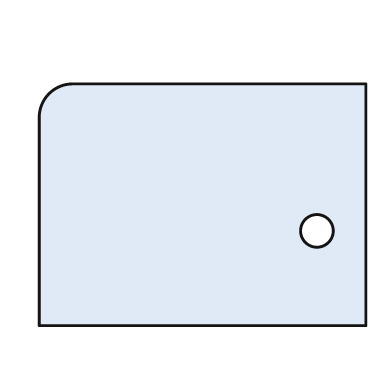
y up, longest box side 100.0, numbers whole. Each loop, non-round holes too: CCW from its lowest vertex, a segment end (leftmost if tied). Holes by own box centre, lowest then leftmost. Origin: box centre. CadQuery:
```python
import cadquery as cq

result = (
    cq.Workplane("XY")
    .moveTo(-50.0, -37.0)
    .lineTo(50.0, -37.0)
    .lineTo(50.0, 37.0)
    .lineTo(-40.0, 37.0)
    .threePointArc((-47.0, 34.0), (-50.0, 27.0))
    .close()
    .moveTo(35.0, -8.0)
    .circle(5.0)
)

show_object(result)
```